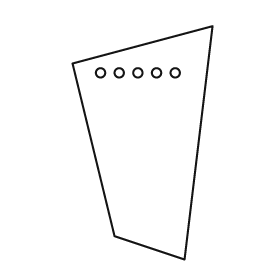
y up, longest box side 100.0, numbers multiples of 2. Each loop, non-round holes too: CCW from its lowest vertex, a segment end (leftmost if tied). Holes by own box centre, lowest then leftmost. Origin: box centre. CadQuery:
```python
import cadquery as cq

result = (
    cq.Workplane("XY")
    .moveTo(18.0, -50.0)
    .lineTo(30.0, 50.0)
    .lineTo(-30.0, 34.0)
    .lineTo(-12.0, -40.0)
    .close()
    .moveTo(-18.0, 30.0)
    .circle(2.0)
    .moveTo(-10.0, 30.0)
    .circle(2.0)
    .moveTo(-2.0, 30.0)
    .circle(2.0)
    .moveTo(6.0, 30.0)
    .circle(2.0)
    .moveTo(14.0, 30.0)
    .circle(2.0)
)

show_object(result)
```